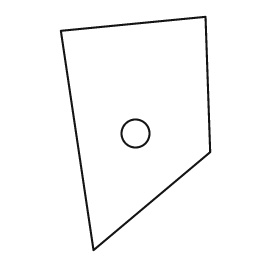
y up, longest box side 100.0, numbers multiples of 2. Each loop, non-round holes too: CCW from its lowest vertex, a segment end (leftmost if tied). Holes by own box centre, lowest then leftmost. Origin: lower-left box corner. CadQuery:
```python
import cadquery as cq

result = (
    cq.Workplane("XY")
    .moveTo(14.0, 0.0)
    .lineTo(64.0, 42.0)
    .lineTo(62.0, 100.0)
    .lineTo(0.0, 94.0)
    .close()
    .moveTo(32.0, 50.0)
    .circle(6.0)
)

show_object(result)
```